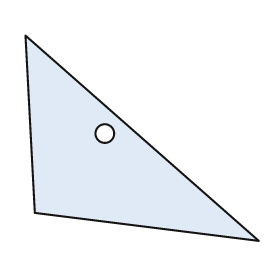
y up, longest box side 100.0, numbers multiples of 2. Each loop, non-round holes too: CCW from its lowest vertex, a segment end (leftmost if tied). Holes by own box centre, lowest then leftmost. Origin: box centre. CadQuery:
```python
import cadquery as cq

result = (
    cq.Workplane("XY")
    .moveTo(50.0, -44.0)
    .lineTo(-50.0, 44.0)
    .lineTo(-46.0, -32.0)
    .close()
    .moveTo(-16.0, 2.0)
    .circle(4.0)
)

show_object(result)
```